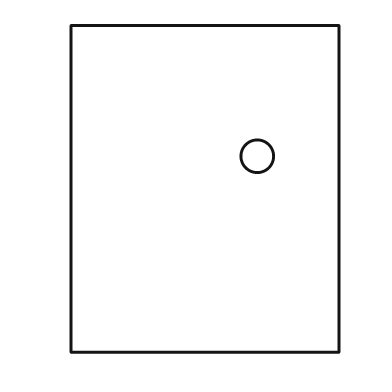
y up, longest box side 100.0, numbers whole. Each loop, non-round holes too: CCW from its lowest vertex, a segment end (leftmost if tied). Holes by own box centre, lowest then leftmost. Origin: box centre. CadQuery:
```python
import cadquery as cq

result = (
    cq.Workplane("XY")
    .moveTo(-41.0, -50.0)
    .lineTo(41.0, -50.0)
    .lineTo(41.0, 50.0)
    .lineTo(-41.0, 50.0)
    .close()
    .moveTo(16.0, 10.0)
    .circle(5.0)
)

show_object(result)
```